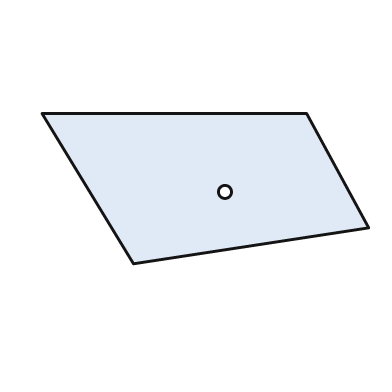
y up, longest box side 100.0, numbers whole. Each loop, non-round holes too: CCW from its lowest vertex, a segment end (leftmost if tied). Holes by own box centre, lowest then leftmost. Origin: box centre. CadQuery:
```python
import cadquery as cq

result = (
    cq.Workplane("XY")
    .moveTo(-22.0, -23.0)
    .lineTo(50.0, -12.0)
    .lineTo(31.0, 23.0)
    .lineTo(-50.0, 23.0)
    .close()
    .moveTo(6.0, -1.0)
    .circle(2.0)
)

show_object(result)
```